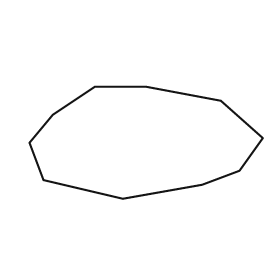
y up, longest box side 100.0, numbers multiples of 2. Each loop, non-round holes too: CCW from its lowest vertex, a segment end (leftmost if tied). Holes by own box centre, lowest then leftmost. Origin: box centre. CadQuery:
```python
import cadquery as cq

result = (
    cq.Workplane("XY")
    .moveTo(-10.0, -24.0)
    .lineTo(24.0, -18.0)
    .lineTo(40.0, -12.0)
    .lineTo(50.0, 2.0)
    .lineTo(32.0, 18.0)
    .lineTo(0.0, 24.0)
    .lineTo(-22.0, 24.0)
    .lineTo(-40.0, 12.0)
    .lineTo(-50.0, 0.0)
    .lineTo(-44.0, -16.0)
    .close()
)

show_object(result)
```